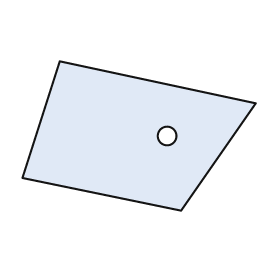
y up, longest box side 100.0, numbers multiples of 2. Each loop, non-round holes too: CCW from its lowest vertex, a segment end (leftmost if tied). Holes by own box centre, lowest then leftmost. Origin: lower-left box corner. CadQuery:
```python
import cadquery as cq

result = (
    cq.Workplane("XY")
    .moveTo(68.0, 0.0)
    .lineTo(100.0, 46.0)
    .lineTo(16.0, 64.0)
    .lineTo(0.0, 14.0)
    .close()
    .moveTo(62.0, 32.0)
    .circle(4.0)
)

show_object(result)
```